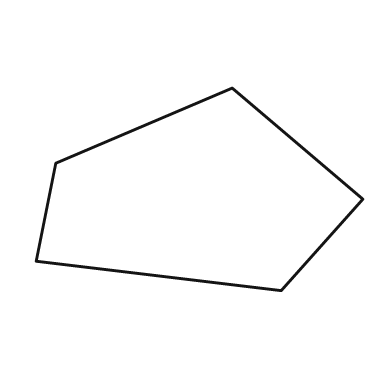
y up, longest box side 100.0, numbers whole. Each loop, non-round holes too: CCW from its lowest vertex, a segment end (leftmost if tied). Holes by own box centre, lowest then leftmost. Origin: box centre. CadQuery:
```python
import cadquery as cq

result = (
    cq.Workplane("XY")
    .moveTo(25.0, -31.0)
    .lineTo(50.0, -3.0)
    .lineTo(10.0, 31.0)
    .lineTo(-44.0, 8.0)
    .lineTo(-50.0, -22.0)
    .close()
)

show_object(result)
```